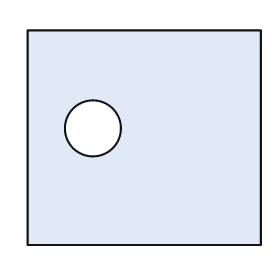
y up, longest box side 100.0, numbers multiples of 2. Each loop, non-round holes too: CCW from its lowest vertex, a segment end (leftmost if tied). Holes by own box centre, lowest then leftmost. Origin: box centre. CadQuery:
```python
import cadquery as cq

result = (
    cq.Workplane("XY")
    .moveTo(-50.0, -46.0)
    .lineTo(50.0, -46.0)
    .lineTo(50.0, 46.0)
    .lineTo(-50.0, 46.0)
    .close()
    .moveTo(-22.0, 4.0)
    .circle(12.0)
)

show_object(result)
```